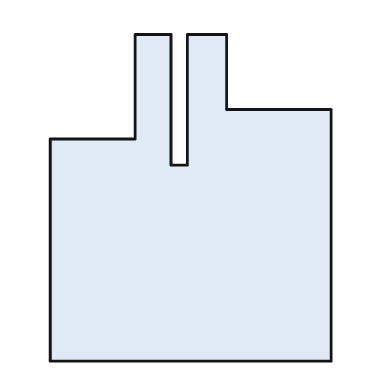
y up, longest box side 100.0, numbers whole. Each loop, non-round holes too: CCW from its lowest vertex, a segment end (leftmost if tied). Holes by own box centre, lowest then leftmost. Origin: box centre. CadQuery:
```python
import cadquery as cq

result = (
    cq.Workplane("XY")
    .moveTo(-43.0, -50.0)
    .lineTo(43.0, -50.0)
    .lineTo(43.0, 27.0)
    .lineTo(11.0, 27.0)
    .lineTo(11.0, 50.0)
    .lineTo(-1.0, 50.0)
    .lineTo(-1.0, 10.0)
    .lineTo(-6.0, 10.0)
    .lineTo(-6.0, 50.0)
    .lineTo(-17.0, 50.0)
    .lineTo(-17.0, 18.0)
    .lineTo(-43.0, 18.0)
    .close()
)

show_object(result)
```